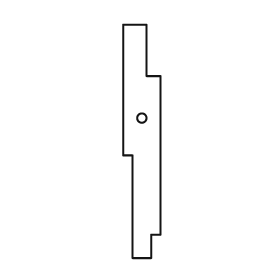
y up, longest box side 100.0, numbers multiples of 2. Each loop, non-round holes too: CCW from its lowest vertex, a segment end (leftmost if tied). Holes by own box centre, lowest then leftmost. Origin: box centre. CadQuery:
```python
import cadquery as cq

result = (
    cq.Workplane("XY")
    .moveTo(-4.0, -50.0)
    .lineTo(4.0, -50.0)
    .lineTo(4.0, -40.0)
    .lineTo(8.0, -40.0)
    .lineTo(8.0, 28.0)
    .lineTo(2.0, 28.0)
    .lineTo(2.0, 50.0)
    .lineTo(-8.0, 50.0)
    .lineTo(-8.0, -6.0)
    .lineTo(-4.0, -6.0)
    .close()
    .moveTo(0.0, 10.0)
    .circle(2.0)
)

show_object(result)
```